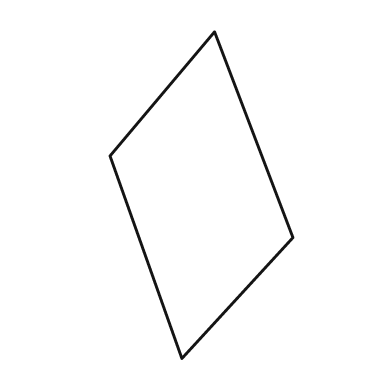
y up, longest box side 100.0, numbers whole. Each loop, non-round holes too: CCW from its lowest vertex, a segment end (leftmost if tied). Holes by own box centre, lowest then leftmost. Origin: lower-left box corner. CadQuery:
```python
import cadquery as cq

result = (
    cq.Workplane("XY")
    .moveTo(22.0, 0.0)
    .lineTo(56.0, 37.0)
    .lineTo(32.0, 100.0)
    .lineTo(0.0, 62.0)
    .close()
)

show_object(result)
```